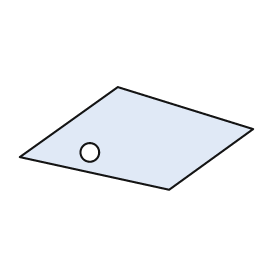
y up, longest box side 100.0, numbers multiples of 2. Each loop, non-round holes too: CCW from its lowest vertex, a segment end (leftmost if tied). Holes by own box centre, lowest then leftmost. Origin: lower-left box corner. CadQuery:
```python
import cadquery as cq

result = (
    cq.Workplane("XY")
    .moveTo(64.0, 0.0)
    .lineTo(100.0, 26.0)
    .lineTo(42.0, 44.0)
    .lineTo(0.0, 14.0)
    .close()
    .moveTo(30.0, 16.0)
    .circle(4.0)
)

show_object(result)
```